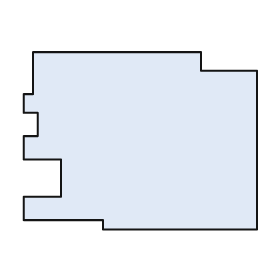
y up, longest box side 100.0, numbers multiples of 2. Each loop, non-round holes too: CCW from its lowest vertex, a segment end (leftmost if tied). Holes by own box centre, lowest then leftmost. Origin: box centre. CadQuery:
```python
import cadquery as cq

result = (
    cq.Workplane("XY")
    .moveTo(-16.0, -38.0)
    .lineTo(50.0, -38.0)
    .lineTo(50.0, 30.0)
    .lineTo(26.0, 30.0)
    .lineTo(26.0, 38.0)
    .lineTo(-46.0, 38.0)
    .lineTo(-46.0, 20.0)
    .lineTo(-50.0, 20.0)
    .lineTo(-50.0, 12.0)
    .lineTo(-44.0, 12.0)
    .lineTo(-44.0, 2.0)
    .lineTo(-50.0, 2.0)
    .lineTo(-50.0, -8.0)
    .lineTo(-34.0, -8.0)
    .lineTo(-34.0, -24.0)
    .lineTo(-50.0, -24.0)
    .lineTo(-50.0, -34.0)
    .lineTo(-16.0, -34.0)
    .close()
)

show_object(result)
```